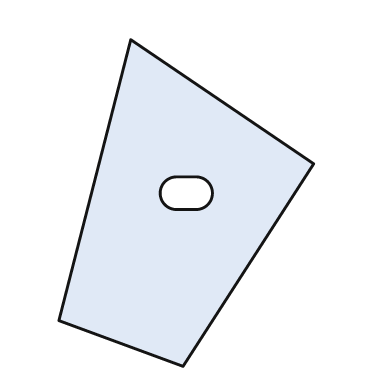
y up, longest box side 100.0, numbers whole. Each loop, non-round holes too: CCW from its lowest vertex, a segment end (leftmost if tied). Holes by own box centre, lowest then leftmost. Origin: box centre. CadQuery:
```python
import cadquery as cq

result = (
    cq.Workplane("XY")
    .moveTo(-1.0, -50.0)
    .lineTo(39.0, 12.0)
    .lineTo(-17.0, 50.0)
    .lineTo(-39.0, -36.0)
    .close()
    .moveTo(-3.0, -2.0)
    .lineTo(3.0, -2.0)
    .threePointArc((8.0, 3.0), (3.0, 8.0))
    .lineTo(-3.0, 8.0)
    .threePointArc((-8.0, 3.0), (-3.0, -2.0))
    .close()
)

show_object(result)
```